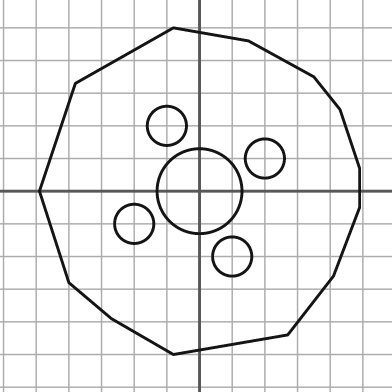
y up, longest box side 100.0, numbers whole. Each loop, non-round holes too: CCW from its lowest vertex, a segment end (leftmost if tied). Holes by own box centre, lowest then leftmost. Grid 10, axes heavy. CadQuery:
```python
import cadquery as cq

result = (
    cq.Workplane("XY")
    .moveTo(-8.0, -50.0)
    .lineTo(27.0, -44.0)
    .lineTo(41.0, -26.0)
    .lineTo(49.0, -5.0)
    .lineTo(49.0, 7.0)
    .lineTo(43.0, 25.0)
    .lineTo(35.0, 35.0)
    .lineTo(15.0, 46.0)
    .lineTo(-8.0, 50.0)
    .lineTo(-38.0, 33.0)
    .lineTo(-49.0, 0.0)
    .lineTo(-40.0, -28.0)
    .lineTo(-27.0, -39.0)
    .close()
    .moveTo(10.0, -20.0)
    .circle(6.0)
    .moveTo(-20.0, -10.0)
    .circle(6.0)
    .moveTo(0.0, 0.0)
    .circle(13.0)
    .moveTo(20.0, 10.0)
    .circle(6.0)
    .moveTo(-10.0, 20.0)
    .circle(6.0)
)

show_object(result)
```